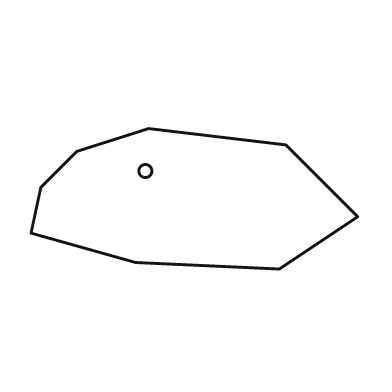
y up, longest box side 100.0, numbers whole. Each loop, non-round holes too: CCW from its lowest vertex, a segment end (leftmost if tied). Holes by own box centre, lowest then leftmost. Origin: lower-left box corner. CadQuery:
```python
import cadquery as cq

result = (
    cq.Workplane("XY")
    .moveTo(76.0, 0.0)
    .lineTo(100.0, 16.0)
    .lineTo(78.0, 38.0)
    .lineTo(36.0, 43.0)
    .lineTo(14.0, 36.0)
    .lineTo(3.0, 25.0)
    .lineTo(0.0, 11.0)
    .lineTo(32.0, 2.0)
    .close()
    .moveTo(35.0, 30.0)
    .circle(2.0)
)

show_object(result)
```